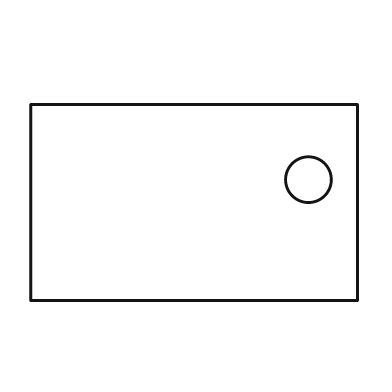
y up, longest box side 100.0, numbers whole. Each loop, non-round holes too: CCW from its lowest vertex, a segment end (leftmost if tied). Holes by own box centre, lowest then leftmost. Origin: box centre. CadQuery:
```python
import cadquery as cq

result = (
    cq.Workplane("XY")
    .moveTo(-50.0, -30.0)
    .lineTo(50.0, -30.0)
    .lineTo(50.0, 30.0)
    .lineTo(-50.0, 30.0)
    .close()
    .moveTo(35.0, 7.0)
    .circle(7.0)
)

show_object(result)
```